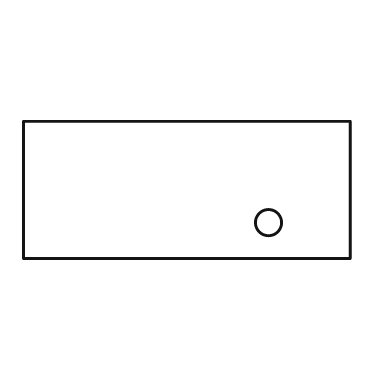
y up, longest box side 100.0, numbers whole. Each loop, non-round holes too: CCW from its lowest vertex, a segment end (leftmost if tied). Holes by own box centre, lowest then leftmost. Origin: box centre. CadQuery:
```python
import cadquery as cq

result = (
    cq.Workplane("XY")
    .moveTo(-50.0, -21.0)
    .lineTo(50.0, -21.0)
    .lineTo(50.0, 21.0)
    .lineTo(-50.0, 21.0)
    .close()
    .moveTo(25.0, -10.0)
    .circle(4.0)
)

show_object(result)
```